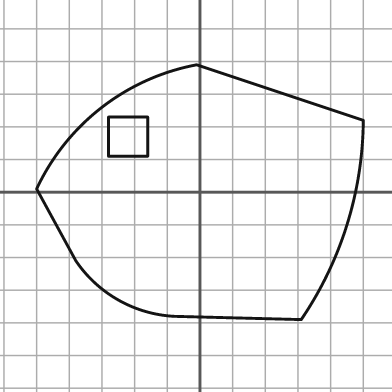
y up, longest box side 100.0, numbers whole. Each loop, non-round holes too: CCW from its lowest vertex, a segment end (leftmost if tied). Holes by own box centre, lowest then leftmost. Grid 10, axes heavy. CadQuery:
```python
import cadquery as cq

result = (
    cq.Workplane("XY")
    .moveTo(31.0, -39.0)
    .threePointArc((45.0, -10.0), (50.0, 22.0))
    .lineTo(-1.0, 39.0)
    .threePointArc((-30.0, 26.0), (-50.0, 1.0))
    .lineTo(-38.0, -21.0)
    .threePointArc((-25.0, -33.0), (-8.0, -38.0))
    .close()
    .moveTo(-28.0, 11.0)
    .lineTo(-16.0, 11.0)
    .lineTo(-16.0, 23.0)
    .lineTo(-28.0, 23.0)
    .close()
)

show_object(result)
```